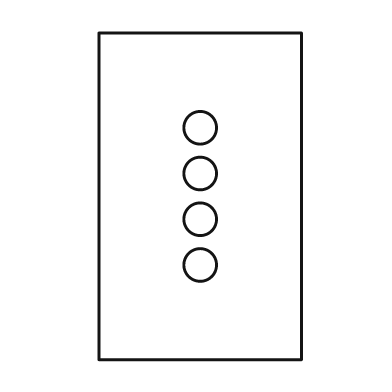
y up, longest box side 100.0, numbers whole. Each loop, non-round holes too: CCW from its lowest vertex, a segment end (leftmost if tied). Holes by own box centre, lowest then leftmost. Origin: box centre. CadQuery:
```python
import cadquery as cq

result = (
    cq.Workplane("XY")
    .moveTo(-31.0, -50.0)
    .lineTo(31.0, -50.0)
    .lineTo(31.0, 50.0)
    .lineTo(-31.0, 50.0)
    .close()
    .moveTo(0.0, -21.0)
    .circle(5.0)
    .moveTo(0.0, -7.0)
    .circle(5.0)
    .moveTo(0.0, 7.0)
    .circle(5.0)
    .moveTo(0.0, 21.0)
    .circle(5.0)
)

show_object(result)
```